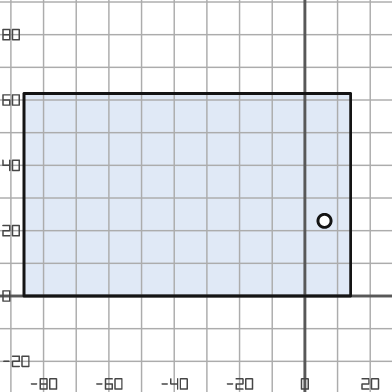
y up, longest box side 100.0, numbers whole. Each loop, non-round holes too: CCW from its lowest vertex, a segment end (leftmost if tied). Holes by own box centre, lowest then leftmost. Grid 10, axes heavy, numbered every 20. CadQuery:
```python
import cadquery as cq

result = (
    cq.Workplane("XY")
    .moveTo(-86.0, 0.0)
    .lineTo(14.0, 0.0)
    .lineTo(14.0, 62.0)
    .lineTo(-86.0, 62.0)
    .close()
    .moveTo(6.0, 23.0)
    .circle(2.0)
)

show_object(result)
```